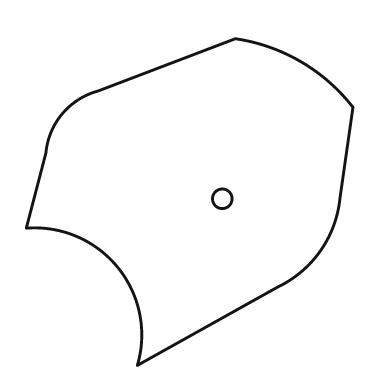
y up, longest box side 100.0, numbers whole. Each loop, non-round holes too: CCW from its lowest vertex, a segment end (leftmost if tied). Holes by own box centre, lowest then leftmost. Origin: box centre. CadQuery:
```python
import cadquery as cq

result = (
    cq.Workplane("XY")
    .moveTo(-16.0, -50.0)
    .lineTo(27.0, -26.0)
    .threePointArc((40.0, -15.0), (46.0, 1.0))
    .lineTo(50.0, 29.0)
    .threePointArc((34.0, 43.0), (14.0, 50.0))
    .lineTo(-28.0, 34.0)
    .threePointArc((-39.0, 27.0), (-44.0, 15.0))
    .lineTo(-50.0, -8.0)
    .threePointArc((-22.0, -20.0), (-16.0, -50.0))
    .close()
    .moveTo(10.0, 1.0)
    .circle(3.0)
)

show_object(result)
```